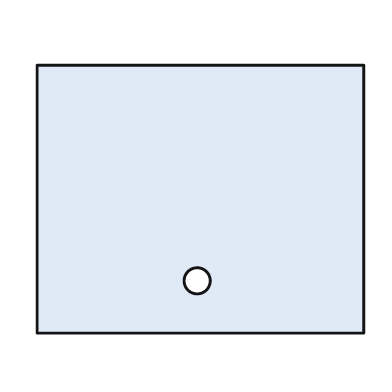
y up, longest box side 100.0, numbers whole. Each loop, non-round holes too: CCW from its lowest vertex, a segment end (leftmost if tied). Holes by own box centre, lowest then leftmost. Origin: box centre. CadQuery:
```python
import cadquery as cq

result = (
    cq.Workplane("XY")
    .moveTo(-50.0, -41.0)
    .lineTo(50.0, -41.0)
    .lineTo(50.0, 41.0)
    .lineTo(-50.0, 41.0)
    .close()
    .moveTo(-1.0, -25.0)
    .circle(4.0)
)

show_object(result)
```